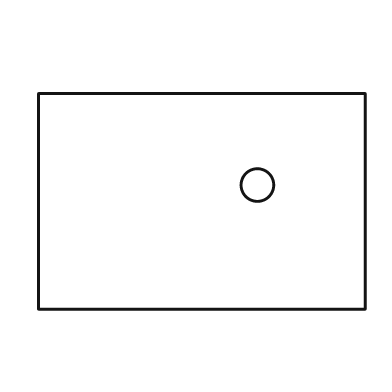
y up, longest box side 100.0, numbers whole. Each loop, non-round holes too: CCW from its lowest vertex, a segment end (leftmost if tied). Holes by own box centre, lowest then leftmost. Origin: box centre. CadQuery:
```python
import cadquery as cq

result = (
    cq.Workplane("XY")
    .moveTo(-50.0, -33.0)
    .lineTo(50.0, -33.0)
    .lineTo(50.0, 33.0)
    .lineTo(-50.0, 33.0)
    .close()
    .moveTo(17.0, 5.0)
    .circle(5.0)
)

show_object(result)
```